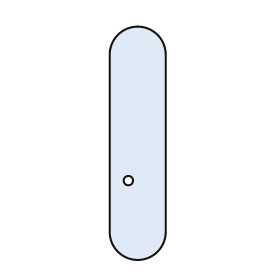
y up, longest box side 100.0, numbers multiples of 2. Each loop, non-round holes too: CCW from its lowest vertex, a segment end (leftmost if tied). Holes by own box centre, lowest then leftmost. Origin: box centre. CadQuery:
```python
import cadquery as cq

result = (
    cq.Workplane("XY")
    .moveTo(-12.0, -38.0)
    .threePointArc((0.0, -50.0), (12.0, -38.0))
    .lineTo(12.0, 38.0)
    .threePointArc((0.0, 50.0), (-12.0, 38.0))
    .close()
    .moveTo(-4.0, -16.0)
    .circle(2.0)
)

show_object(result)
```